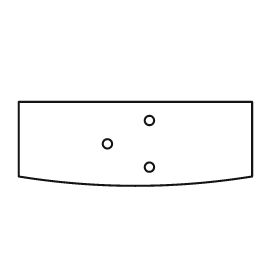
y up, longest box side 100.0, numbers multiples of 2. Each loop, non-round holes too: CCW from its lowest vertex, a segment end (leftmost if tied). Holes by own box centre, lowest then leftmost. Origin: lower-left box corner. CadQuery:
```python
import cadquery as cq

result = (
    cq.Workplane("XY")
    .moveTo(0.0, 4.0)
    .threePointArc((50.0, 0.0), (100.0, 4.0))
    .lineTo(100.0, 36.0)
    .lineTo(0.0, 36.0)
    .close()
    .moveTo(56.0, 8.0)
    .circle(2.0)
    .moveTo(38.0, 18.0)
    .circle(2.0)
    .moveTo(56.0, 28.0)
    .circle(2.0)
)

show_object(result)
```